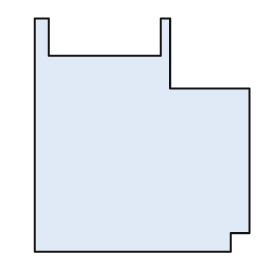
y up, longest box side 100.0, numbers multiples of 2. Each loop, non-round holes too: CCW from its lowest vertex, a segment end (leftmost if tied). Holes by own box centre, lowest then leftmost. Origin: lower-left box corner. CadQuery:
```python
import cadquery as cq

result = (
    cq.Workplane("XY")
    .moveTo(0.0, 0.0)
    .lineTo(84.0, 0.0)
    .lineTo(84.0, 8.0)
    .lineTo(92.0, 8.0)
    .lineTo(92.0, 70.0)
    .lineTo(58.0, 70.0)
    .lineTo(58.0, 100.0)
    .lineTo(54.0, 100.0)
    .lineTo(54.0, 84.0)
    .lineTo(6.0, 84.0)
    .lineTo(6.0, 100.0)
    .lineTo(0.0, 100.0)
    .close()
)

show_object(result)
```